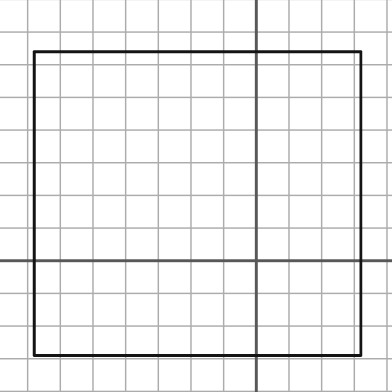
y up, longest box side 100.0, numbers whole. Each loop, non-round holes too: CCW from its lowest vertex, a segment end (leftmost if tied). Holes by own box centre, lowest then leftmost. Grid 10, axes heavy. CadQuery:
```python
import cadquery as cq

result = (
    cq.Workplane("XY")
    .moveTo(-68.0, -29.0)
    .lineTo(32.0, -29.0)
    .lineTo(32.0, 64.0)
    .lineTo(-68.0, 64.0)
    .close()
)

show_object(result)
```